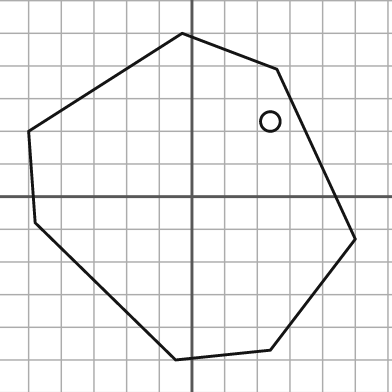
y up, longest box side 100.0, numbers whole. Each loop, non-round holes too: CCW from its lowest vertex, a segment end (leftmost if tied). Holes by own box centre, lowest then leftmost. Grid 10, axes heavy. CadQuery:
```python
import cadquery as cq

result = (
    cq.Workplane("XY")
    .moveTo(-5.0, -50.0)
    .lineTo(24.0, -47.0)
    .lineTo(50.0, -13.0)
    .lineTo(26.0, 39.0)
    .lineTo(-3.0, 50.0)
    .lineTo(-50.0, 20.0)
    .lineTo(-48.0, -8.0)
    .close()
    .moveTo(24.0, 23.0)
    .circle(3.0)
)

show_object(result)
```